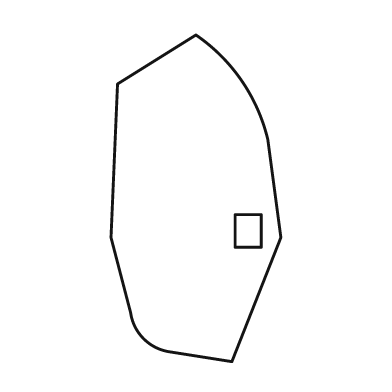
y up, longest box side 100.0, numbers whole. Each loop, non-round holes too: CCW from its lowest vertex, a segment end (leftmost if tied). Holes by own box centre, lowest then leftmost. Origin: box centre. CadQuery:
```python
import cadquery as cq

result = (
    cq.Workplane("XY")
    .moveTo(11.0, -50.0)
    .lineTo(26.0, -12.0)
    .lineTo(22.0, 18.0)
    .threePointArc((14.0, 36.0), (0.0, 50.0))
    .lineTo(-24.0, 35.0)
    .lineTo(-26.0, -12.0)
    .lineTo(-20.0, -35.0)
    .threePointArc((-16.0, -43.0), (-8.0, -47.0))
    .close()
    .moveTo(12.0, -15.0)
    .lineTo(20.0, -15.0)
    .lineTo(20.0, -5.0)
    .lineTo(12.0, -5.0)
    .close()
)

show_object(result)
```